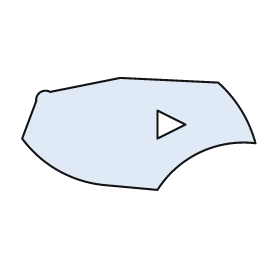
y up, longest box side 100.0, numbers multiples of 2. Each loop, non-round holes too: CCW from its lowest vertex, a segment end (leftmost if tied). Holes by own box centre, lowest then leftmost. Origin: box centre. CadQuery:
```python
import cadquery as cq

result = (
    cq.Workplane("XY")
    .moveTo(8.0, -24.0)
    .threePointArc((26.0, -8.0), (50.0, -4.0))
    .threePointArc((44.0, 10.0), (34.0, 22.0))
    .lineTo(-8.0, 24.0)
    .lineTo(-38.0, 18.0)
    .threePointArc((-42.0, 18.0), (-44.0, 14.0))
    .lineTo(-50.0, -2.0)
    .threePointArc((-34.0, -16.0), (-14.0, -22.0))
    .close()
    .moveTo(8.0, -2.0)
    .lineTo(20.0, 4.0)
    .lineTo(8.0, 10.0)
    .close()
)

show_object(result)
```